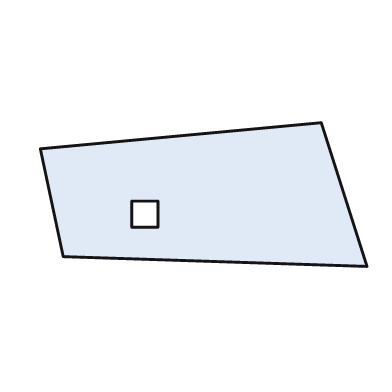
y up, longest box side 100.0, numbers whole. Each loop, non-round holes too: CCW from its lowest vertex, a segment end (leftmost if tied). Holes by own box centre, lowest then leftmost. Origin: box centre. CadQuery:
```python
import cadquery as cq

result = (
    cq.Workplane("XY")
    .moveTo(50.0, -22.0)
    .lineTo(36.0, 22.0)
    .lineTo(-50.0, 14.0)
    .lineTo(-43.0, -19.0)
    .close()
    .moveTo(-22.0, -10.0)
    .lineTo(-14.0, -10.0)
    .lineTo(-14.0, -2.0)
    .lineTo(-22.0, -2.0)
    .close()
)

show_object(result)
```